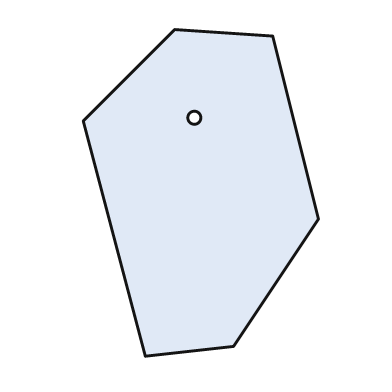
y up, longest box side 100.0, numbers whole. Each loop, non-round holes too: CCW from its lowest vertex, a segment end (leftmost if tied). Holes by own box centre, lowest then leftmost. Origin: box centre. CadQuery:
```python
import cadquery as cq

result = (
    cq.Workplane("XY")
    .moveTo(-17.0, -50.0)
    .lineTo(10.0, -47.0)
    .lineTo(36.0, -8.0)
    .lineTo(22.0, 48.0)
    .lineTo(-8.0, 50.0)
    .lineTo(-36.0, 22.0)
    .close()
    .moveTo(-2.0, 23.0)
    .circle(2.0)
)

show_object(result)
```